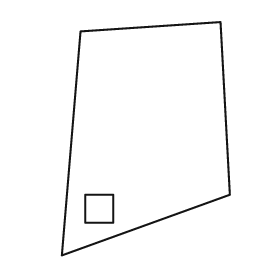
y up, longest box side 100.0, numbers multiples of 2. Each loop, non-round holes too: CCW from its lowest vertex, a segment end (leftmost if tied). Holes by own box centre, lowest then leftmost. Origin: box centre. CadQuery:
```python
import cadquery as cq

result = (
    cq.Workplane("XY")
    .moveTo(-36.0, -50.0)
    .lineTo(36.0, -24.0)
    .lineTo(32.0, 50.0)
    .lineTo(-28.0, 46.0)
    .close()
    .moveTo(-26.0, -36.0)
    .lineTo(-14.0, -36.0)
    .lineTo(-14.0, -24.0)
    .lineTo(-26.0, -24.0)
    .close()
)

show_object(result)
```